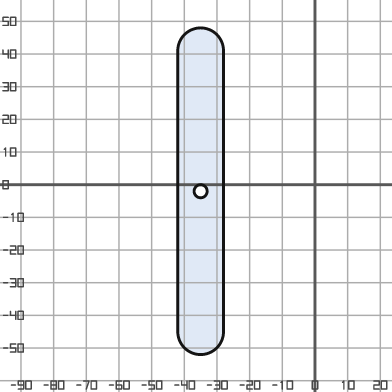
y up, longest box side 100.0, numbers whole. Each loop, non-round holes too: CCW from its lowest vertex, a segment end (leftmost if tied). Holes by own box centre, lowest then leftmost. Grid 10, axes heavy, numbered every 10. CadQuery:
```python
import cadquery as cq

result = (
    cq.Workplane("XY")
    .moveTo(-42.0, -45.0)
    .threePointArc((-35.0, -52.0), (-28.0, -45.0))
    .lineTo(-28.0, 41.0)
    .threePointArc((-35.0, 48.0), (-42.0, 41.0))
    .close()
    .moveTo(-35.0, -2.0)
    .circle(2.0)
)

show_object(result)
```